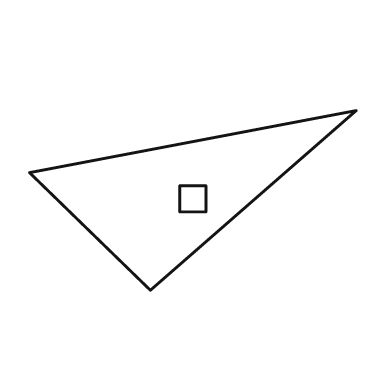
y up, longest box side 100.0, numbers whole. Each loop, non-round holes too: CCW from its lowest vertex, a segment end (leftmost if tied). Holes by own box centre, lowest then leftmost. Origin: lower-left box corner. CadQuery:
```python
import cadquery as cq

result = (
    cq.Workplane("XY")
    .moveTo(37.0, 0.0)
    .lineTo(100.0, 55.0)
    .lineTo(0.0, 36.0)
    .close()
    .moveTo(46.0, 24.0)
    .lineTo(54.0, 24.0)
    .lineTo(54.0, 32.0)
    .lineTo(46.0, 32.0)
    .close()
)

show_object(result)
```